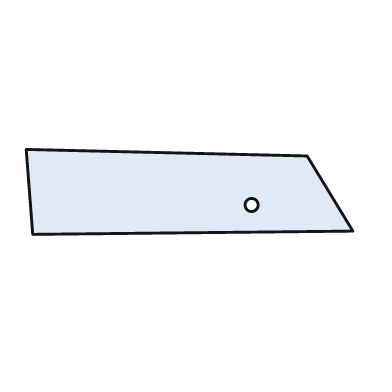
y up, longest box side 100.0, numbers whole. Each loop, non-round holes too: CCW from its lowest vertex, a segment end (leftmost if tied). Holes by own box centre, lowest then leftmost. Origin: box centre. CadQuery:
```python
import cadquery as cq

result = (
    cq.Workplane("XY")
    .moveTo(-48.0, -13.0)
    .lineTo(50.0, -12.0)
    .lineTo(36.0, 11.0)
    .lineTo(-50.0, 13.0)
    .close()
    .moveTo(19.0, -4.0)
    .circle(2.0)
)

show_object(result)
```